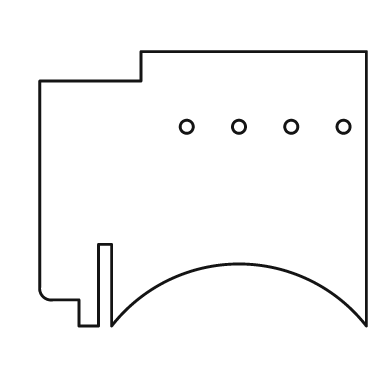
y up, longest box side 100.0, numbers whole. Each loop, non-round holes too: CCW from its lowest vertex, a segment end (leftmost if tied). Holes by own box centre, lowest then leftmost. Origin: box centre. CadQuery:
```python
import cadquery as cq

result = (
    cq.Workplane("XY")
    .moveTo(-38.0, -42.0)
    .lineTo(-32.0, -42.0)
    .lineTo(-32.0, -17.0)
    .lineTo(-28.0, -17.0)
    .lineTo(-28.0, -42.0)
    .threePointArc((11.0, -23.0), (50.0, -42.0))
    .lineTo(50.0, 42.0)
    .lineTo(-19.0, 42.0)
    .lineTo(-19.0, 33.0)
    .lineTo(-50.0, 33.0)
    .lineTo(-50.0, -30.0)
    .threePointArc((-49.0, -33.0), (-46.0, -34.0))
    .lineTo(-38.0, -34.0)
    .close()
    .moveTo(-5.0, 19.0)
    .circle(2.0)
    .moveTo(11.0, 19.0)
    .circle(2.0)
    .moveTo(27.0, 19.0)
    .circle(2.0)
    .moveTo(43.0, 19.0)
    .circle(2.0)
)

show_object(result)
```